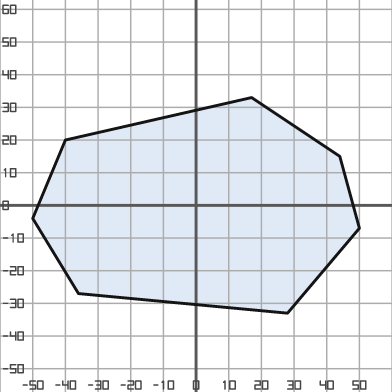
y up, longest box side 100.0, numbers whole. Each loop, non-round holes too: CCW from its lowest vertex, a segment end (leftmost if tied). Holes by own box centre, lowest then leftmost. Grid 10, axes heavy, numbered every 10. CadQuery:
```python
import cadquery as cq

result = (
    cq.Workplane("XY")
    .moveTo(28.0, -33.0)
    .lineTo(50.0, -7.0)
    .lineTo(44.0, 15.0)
    .lineTo(17.0, 33.0)
    .lineTo(-40.0, 20.0)
    .lineTo(-50.0, -4.0)
    .lineTo(-36.0, -27.0)
    .close()
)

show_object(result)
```